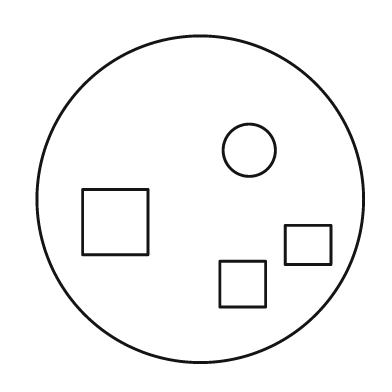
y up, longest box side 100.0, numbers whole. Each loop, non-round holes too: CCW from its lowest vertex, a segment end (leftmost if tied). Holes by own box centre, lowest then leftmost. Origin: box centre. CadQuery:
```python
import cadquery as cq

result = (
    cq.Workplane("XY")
    .moveTo(0.0, 0.0)
    .circle(50.0)
    .moveTo(6.0, -33.0)
    .lineTo(20.0, -33.0)
    .lineTo(20.0, -19.0)
    .lineTo(6.0, -19.0)
    .close()
    .moveTo(26.0, -20.0)
    .lineTo(40.0, -20.0)
    .lineTo(40.0, -8.0)
    .lineTo(26.0, -8.0)
    .close()
    .moveTo(-36.0, -17.0)
    .lineTo(-16.0, -17.0)
    .lineTo(-16.0, 3.0)
    .lineTo(-36.0, 3.0)
    .close()
    .moveTo(15.0, 15.0)
    .circle(8.0)
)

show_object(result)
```